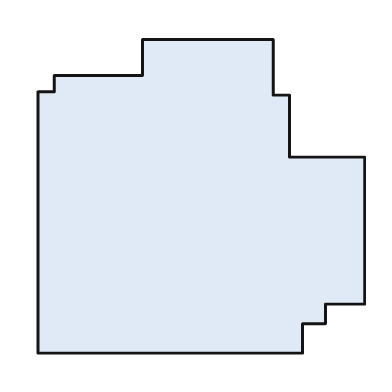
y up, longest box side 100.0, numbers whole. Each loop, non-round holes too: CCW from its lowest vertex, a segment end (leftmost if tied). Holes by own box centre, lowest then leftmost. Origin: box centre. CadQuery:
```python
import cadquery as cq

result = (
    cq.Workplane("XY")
    .moveTo(-50.0, -48.0)
    .lineTo(31.0, -48.0)
    .lineTo(31.0, -39.0)
    .lineTo(38.0, -39.0)
    .lineTo(38.0, -33.0)
    .lineTo(50.0, -33.0)
    .lineTo(50.0, 12.0)
    .lineTo(27.0, 12.0)
    .lineTo(27.0, 31.0)
    .lineTo(22.0, 31.0)
    .lineTo(22.0, 48.0)
    .lineTo(-18.0, 48.0)
    .lineTo(-18.0, 37.0)
    .lineTo(-45.0, 37.0)
    .lineTo(-45.0, 32.0)
    .lineTo(-50.0, 32.0)
    .close()
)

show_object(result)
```